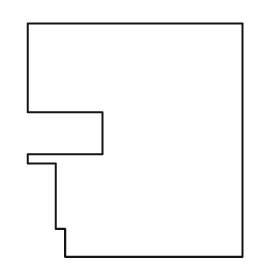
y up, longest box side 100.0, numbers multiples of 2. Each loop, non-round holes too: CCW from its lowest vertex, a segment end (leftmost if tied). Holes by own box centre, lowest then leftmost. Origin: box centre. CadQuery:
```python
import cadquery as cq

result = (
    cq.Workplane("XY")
    .moveTo(-30.0, -50.0)
    .lineTo(46.0, -50.0)
    .lineTo(46.0, 50.0)
    .lineTo(-46.0, 50.0)
    .lineTo(-46.0, 12.0)
    .lineTo(-14.0, 12.0)
    .lineTo(-14.0, -6.0)
    .lineTo(-46.0, -6.0)
    .lineTo(-46.0, -10.0)
    .lineTo(-34.0, -10.0)
    .lineTo(-34.0, -38.0)
    .lineTo(-30.0, -38.0)
    .close()
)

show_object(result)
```